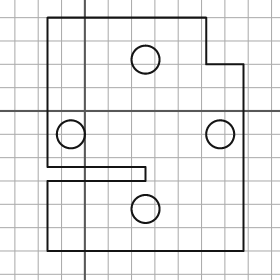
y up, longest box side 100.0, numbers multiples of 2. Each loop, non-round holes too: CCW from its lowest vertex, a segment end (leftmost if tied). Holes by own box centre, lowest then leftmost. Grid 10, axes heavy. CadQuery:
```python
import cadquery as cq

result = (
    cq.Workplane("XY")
    .moveTo(-16.0, -60.0)
    .lineTo(68.0, -60.0)
    .lineTo(68.0, 20.0)
    .lineTo(52.0, 20.0)
    .lineTo(52.0, 40.0)
    .lineTo(-16.0, 40.0)
    .lineTo(-16.0, -24.0)
    .lineTo(26.0, -24.0)
    .lineTo(26.0, -30.0)
    .lineTo(-16.0, -30.0)
    .close()
    .moveTo(26.0, -42.0)
    .circle(6.0)
    .moveTo(-6.0, -10.0)
    .circle(6.0)
    .moveTo(58.0, -10.0)
    .circle(6.0)
    .moveTo(26.0, 22.0)
    .circle(6.0)
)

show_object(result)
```